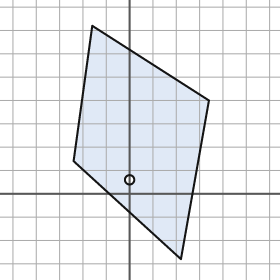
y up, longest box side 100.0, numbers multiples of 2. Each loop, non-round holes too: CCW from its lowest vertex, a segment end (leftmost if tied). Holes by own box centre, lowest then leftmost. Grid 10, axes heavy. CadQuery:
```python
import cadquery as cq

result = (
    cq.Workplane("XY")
    .moveTo(22.0, -28.0)
    .lineTo(34.0, 40.0)
    .lineTo(-16.0, 72.0)
    .lineTo(-24.0, 14.0)
    .close()
    .moveTo(0.0, 6.0)
    .circle(2.0)
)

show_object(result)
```